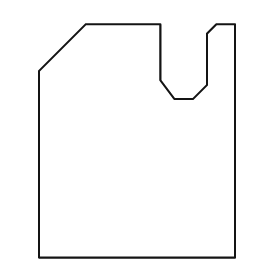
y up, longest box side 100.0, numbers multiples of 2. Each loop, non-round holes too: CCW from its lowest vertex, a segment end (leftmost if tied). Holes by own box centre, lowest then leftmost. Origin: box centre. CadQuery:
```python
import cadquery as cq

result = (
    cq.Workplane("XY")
    .moveTo(-42.0, -50.0)
    .lineTo(42.0, -50.0)
    .lineTo(42.0, 50.0)
    .lineTo(34.0, 50.0)
    .lineTo(30.0, 46.0)
    .lineTo(30.0, 24.0)
    .lineTo(24.0, 18.0)
    .lineTo(16.0, 18.0)
    .lineTo(10.0, 26.0)
    .lineTo(10.0, 50.0)
    .lineTo(-22.0, 50.0)
    .lineTo(-42.0, 30.0)
    .close()
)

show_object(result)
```